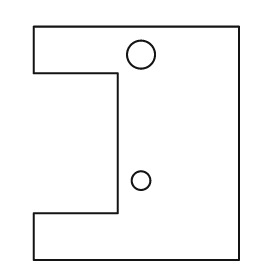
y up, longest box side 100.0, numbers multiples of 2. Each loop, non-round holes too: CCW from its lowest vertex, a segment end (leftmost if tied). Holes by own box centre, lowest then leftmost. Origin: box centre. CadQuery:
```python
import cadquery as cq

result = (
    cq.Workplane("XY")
    .moveTo(-44.0, -50.0)
    .lineTo(44.0, -50.0)
    .lineTo(44.0, 50.0)
    .lineTo(-44.0, 50.0)
    .lineTo(-44.0, 30.0)
    .lineTo(-8.0, 30.0)
    .lineTo(-8.0, -30.0)
    .lineTo(-44.0, -30.0)
    .close()
    .moveTo(2.0, -16.0)
    .circle(4.0)
    .moveTo(2.0, 38.0)
    .circle(6.0)
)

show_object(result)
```